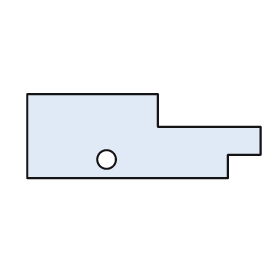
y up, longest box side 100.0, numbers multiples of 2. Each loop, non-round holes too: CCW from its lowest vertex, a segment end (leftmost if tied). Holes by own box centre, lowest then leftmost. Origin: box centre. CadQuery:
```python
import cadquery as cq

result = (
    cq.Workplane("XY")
    .moveTo(-50.0, -18.0)
    .lineTo(36.0, -18.0)
    .lineTo(36.0, -8.0)
    .lineTo(50.0, -8.0)
    .lineTo(50.0, 4.0)
    .lineTo(6.0, 4.0)
    .lineTo(6.0, 18.0)
    .lineTo(-50.0, 18.0)
    .close()
    .moveTo(-16.0, -10.0)
    .circle(4.0)
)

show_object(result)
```